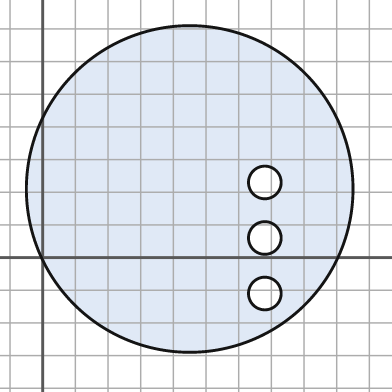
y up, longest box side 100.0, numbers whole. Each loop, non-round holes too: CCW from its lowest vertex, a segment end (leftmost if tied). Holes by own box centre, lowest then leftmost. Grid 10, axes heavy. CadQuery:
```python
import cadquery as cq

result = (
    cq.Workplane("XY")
    .moveTo(45.0, 21.0)
    .circle(50.0)
    .moveTo(68.0, -11.0)
    .circle(5.0)
    .moveTo(68.0, 6.0)
    .circle(5.0)
    .moveTo(68.0, 23.0)
    .circle(5.0)
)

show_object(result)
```